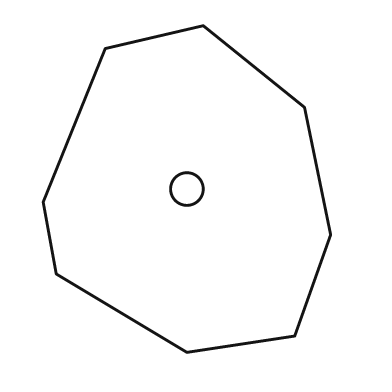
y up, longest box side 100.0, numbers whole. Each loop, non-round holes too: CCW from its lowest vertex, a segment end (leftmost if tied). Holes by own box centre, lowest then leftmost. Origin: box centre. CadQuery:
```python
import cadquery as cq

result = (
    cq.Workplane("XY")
    .moveTo(0.0, -50.0)
    .lineTo(33.0, -45.0)
    .lineTo(44.0, -14.0)
    .lineTo(36.0, 25.0)
    .lineTo(5.0, 50.0)
    .lineTo(-25.0, 43.0)
    .lineTo(-44.0, -4.0)
    .lineTo(-40.0, -26.0)
    .close()
    .moveTo(0.0, 0.0)
    .circle(5.0)
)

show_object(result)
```